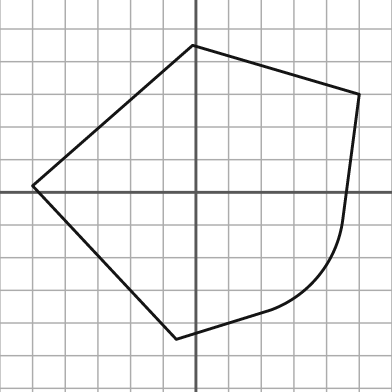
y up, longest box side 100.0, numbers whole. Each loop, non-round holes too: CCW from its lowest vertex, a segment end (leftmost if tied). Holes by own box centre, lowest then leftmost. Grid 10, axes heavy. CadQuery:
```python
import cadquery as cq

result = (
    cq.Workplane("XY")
    .moveTo(-6.0, -45.0)
    .lineTo(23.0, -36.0)
    .threePointArc((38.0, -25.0), (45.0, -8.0))
    .lineTo(50.0, 30.0)
    .lineTo(-1.0, 45.0)
    .lineTo(-50.0, 2.0)
    .close()
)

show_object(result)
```